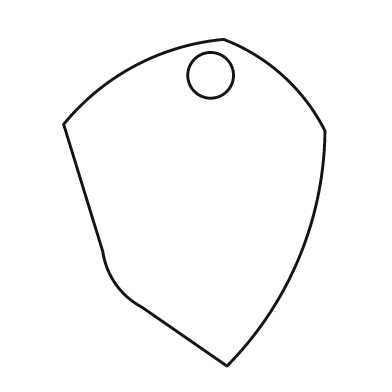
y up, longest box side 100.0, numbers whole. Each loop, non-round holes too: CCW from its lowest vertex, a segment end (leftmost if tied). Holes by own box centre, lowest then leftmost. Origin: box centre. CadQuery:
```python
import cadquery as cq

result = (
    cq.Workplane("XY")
    .moveTo(10.0, -50.0)
    .threePointArc((32.0, -17.0), (40.0, 22.0))
    .threePointArc((27.0, 39.0), (9.0, 50.0))
    .threePointArc((-18.0, 42.0), (-40.0, 24.0))
    .lineTo(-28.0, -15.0)
    .threePointArc((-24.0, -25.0), (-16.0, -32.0))
    .close()
    .moveTo(5.0, 39.0)
    .circle(7.0)
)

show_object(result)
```